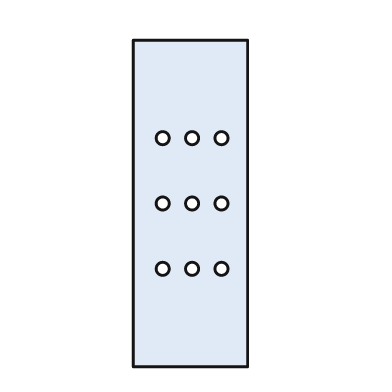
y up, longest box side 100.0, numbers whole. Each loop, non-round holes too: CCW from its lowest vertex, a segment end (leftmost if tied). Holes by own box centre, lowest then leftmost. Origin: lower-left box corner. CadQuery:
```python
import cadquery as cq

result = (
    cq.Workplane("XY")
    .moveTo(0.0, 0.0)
    .lineTo(35.0, 0.0)
    .lineTo(35.0, 100.0)
    .lineTo(0.0, 100.0)
    .close()
    .moveTo(9.0, 30.0)
    .circle(2.0)
    .moveTo(18.0, 30.0)
    .circle(2.0)
    .moveTo(27.0, 30.0)
    .circle(2.0)
    .moveTo(9.0, 50.0)
    .circle(2.0)
    .moveTo(18.0, 50.0)
    .circle(2.0)
    .moveTo(27.0, 50.0)
    .circle(2.0)
    .moveTo(9.0, 70.0)
    .circle(2.0)
    .moveTo(18.0, 70.0)
    .circle(2.0)
    .moveTo(27.0, 70.0)
    .circle(2.0)
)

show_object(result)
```